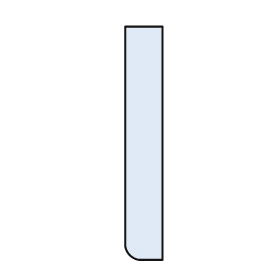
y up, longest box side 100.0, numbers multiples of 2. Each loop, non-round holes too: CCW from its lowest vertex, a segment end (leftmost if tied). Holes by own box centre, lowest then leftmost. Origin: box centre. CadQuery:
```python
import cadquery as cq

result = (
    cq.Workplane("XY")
    .moveTo(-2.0, -50.0)
    .lineTo(8.0, -50.0)
    .lineTo(8.0, 50.0)
    .lineTo(-8.0, 50.0)
    .lineTo(-8.0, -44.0)
    .threePointArc((-6.0, -48.0), (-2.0, -50.0))
    .close()
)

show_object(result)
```